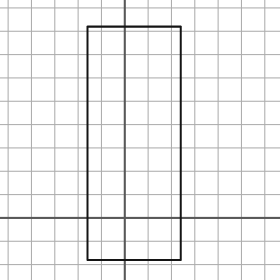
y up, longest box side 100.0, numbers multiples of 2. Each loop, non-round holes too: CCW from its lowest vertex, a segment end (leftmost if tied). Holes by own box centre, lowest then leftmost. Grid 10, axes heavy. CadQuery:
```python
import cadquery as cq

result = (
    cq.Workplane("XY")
    .moveTo(-16.0, -18.0)
    .lineTo(24.0, -18.0)
    .lineTo(24.0, 82.0)
    .lineTo(-16.0, 82.0)
    .close()
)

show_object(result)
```